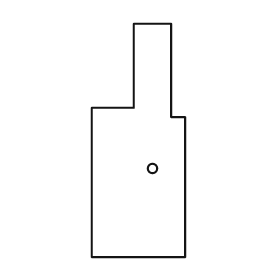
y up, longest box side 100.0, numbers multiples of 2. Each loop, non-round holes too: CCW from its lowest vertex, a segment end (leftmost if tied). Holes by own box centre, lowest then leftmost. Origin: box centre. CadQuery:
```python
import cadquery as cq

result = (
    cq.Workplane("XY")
    .moveTo(-20.0, -50.0)
    .lineTo(20.0, -50.0)
    .lineTo(20.0, 10.0)
    .lineTo(14.0, 10.0)
    .lineTo(14.0, 50.0)
    .lineTo(-2.0, 50.0)
    .lineTo(-2.0, 14.0)
    .lineTo(-20.0, 14.0)
    .close()
    .moveTo(6.0, -12.0)
    .circle(2.0)
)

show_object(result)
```